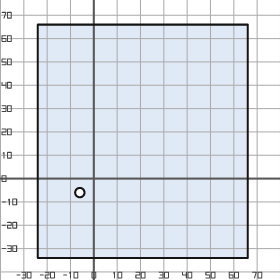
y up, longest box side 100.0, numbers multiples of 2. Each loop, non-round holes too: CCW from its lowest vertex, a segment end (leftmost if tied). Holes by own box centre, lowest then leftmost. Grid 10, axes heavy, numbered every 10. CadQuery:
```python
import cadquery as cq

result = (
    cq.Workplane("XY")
    .moveTo(-24.0, -34.0)
    .lineTo(66.0, -34.0)
    .lineTo(66.0, 66.0)
    .lineTo(-24.0, 66.0)
    .close()
    .moveTo(-6.0, -6.0)
    .circle(2.0)
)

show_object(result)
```